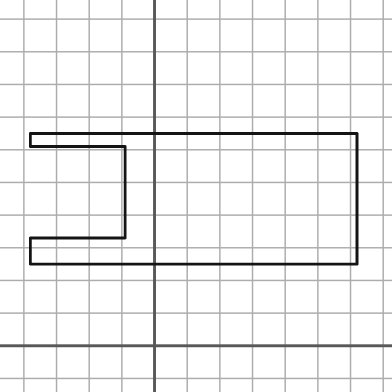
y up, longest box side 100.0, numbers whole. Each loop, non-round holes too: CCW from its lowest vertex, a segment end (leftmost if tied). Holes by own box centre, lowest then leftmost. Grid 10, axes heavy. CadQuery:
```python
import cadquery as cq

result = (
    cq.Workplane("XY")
    .moveTo(-38.0, 25.0)
    .lineTo(62.0, 25.0)
    .lineTo(62.0, 65.0)
    .lineTo(-38.0, 65.0)
    .lineTo(-38.0, 61.0)
    .lineTo(-9.0, 61.0)
    .lineTo(-9.0, 33.0)
    .lineTo(-38.0, 33.0)
    .close()
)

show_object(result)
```